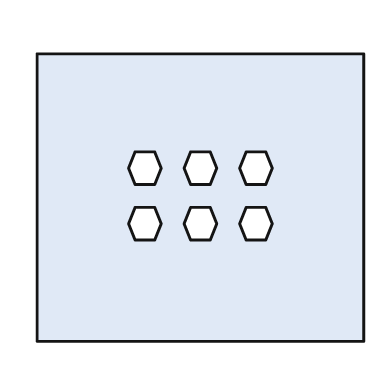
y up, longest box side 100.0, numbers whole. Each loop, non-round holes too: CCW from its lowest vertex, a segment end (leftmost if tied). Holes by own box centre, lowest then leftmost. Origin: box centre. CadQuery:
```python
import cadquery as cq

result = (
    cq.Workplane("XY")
    .moveTo(-50.0, -44.0)
    .lineTo(50.0, -44.0)
    .lineTo(50.0, 44.0)
    .lineTo(-50.0, 44.0)
    .close()
    .moveTo(-20.0, -13.0)
    .lineTo(-14.0, -13.0)
    .lineTo(-12.0, -8.0)
    .lineTo(-14.0, -3.0)
    .lineTo(-20.0, -3.0)
    .lineTo(-22.0, -8.0)
    .close()
    .moveTo(-3.0, -13.0)
    .lineTo(3.0, -13.0)
    .lineTo(5.0, -8.0)
    .lineTo(3.0, -3.0)
    .lineTo(-3.0, -3.0)
    .lineTo(-5.0, -8.0)
    .close()
    .moveTo(14.0, -13.0)
    .lineTo(20.0, -13.0)
    .lineTo(22.0, -8.0)
    .lineTo(20.0, -3.0)
    .lineTo(14.0, -3.0)
    .lineTo(12.0, -8.0)
    .close()
    .moveTo(-20.0, 4.0)
    .lineTo(-14.0, 4.0)
    .lineTo(-12.0, 9.0)
    .lineTo(-14.0, 14.0)
    .lineTo(-20.0, 14.0)
    .lineTo(-22.0, 9.0)
    .close()
    .moveTo(-3.0, 4.0)
    .lineTo(3.0, 4.0)
    .lineTo(5.0, 9.0)
    .lineTo(3.0, 14.0)
    .lineTo(-3.0, 14.0)
    .lineTo(-5.0, 9.0)
    .close()
    .moveTo(14.0, 4.0)
    .lineTo(20.0, 4.0)
    .lineTo(22.0, 9.0)
    .lineTo(20.0, 14.0)
    .lineTo(14.0, 14.0)
    .lineTo(12.0, 9.0)
    .close()
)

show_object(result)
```